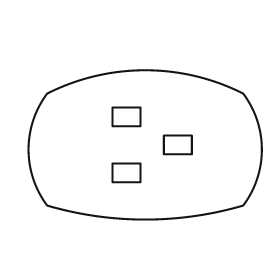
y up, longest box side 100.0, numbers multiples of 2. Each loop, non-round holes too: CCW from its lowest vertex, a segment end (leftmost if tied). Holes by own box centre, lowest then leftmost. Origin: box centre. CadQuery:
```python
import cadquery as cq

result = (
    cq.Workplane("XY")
    .moveTo(-42.0, -26.0)
    .threePointArc((0.0, -32.0), (42.0, -26.0))
    .threePointArc((50.0, -2.0), (42.0, 22.0))
    .threePointArc((0.0, 32.0), (-42.0, 22.0))
    .threePointArc((-50.0, -2.0), (-42.0, -26.0))
    .close()
    .moveTo(-14.0, -16.0)
    .lineTo(-2.0, -16.0)
    .lineTo(-2.0, -8.0)
    .lineTo(-14.0, -8.0)
    .close()
    .moveTo(8.0, -4.0)
    .lineTo(20.0, -4.0)
    .lineTo(20.0, 4.0)
    .lineTo(8.0, 4.0)
    .close()
    .moveTo(-14.0, 8.0)
    .lineTo(-2.0, 8.0)
    .lineTo(-2.0, 16.0)
    .lineTo(-14.0, 16.0)
    .close()
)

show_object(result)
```